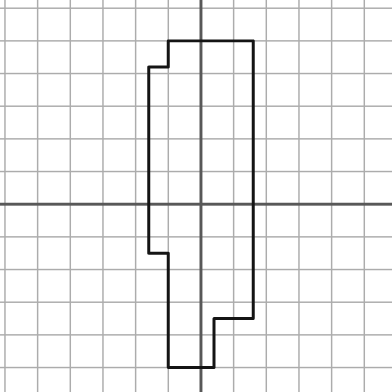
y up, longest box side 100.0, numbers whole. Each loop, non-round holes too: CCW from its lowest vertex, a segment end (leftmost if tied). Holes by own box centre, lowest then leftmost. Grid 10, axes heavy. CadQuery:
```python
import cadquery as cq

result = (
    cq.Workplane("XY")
    .moveTo(-10.0, -50.0)
    .lineTo(4.0, -50.0)
    .lineTo(4.0, -35.0)
    .lineTo(16.0, -35.0)
    .lineTo(16.0, 50.0)
    .lineTo(-10.0, 50.0)
    .lineTo(-10.0, 42.0)
    .lineTo(-16.0, 42.0)
    .lineTo(-16.0, -15.0)
    .lineTo(-10.0, -15.0)
    .close()
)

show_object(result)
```